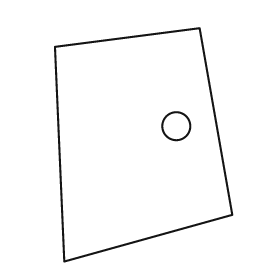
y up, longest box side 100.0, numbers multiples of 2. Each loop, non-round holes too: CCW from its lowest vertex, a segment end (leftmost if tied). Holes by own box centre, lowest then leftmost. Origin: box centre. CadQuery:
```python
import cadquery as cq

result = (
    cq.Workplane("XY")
    .moveTo(-34.0, -50.0)
    .lineTo(38.0, -30.0)
    .lineTo(24.0, 50.0)
    .lineTo(-38.0, 42.0)
    .close()
    .moveTo(14.0, 8.0)
    .circle(6.0)
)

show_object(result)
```